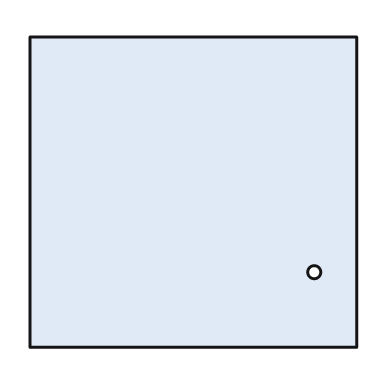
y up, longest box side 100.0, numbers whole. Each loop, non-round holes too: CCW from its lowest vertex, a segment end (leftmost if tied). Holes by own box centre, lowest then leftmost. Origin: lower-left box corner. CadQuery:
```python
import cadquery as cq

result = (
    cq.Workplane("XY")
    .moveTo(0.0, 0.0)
    .lineTo(100.0, 0.0)
    .lineTo(100.0, 95.0)
    .lineTo(0.0, 95.0)
    .close()
    .moveTo(87.0, 23.0)
    .circle(2.0)
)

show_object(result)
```